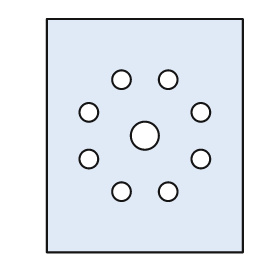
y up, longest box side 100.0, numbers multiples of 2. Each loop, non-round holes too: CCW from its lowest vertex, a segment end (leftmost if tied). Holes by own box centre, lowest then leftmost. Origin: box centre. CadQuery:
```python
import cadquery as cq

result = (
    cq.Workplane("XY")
    .moveTo(-42.0, -50.0)
    .lineTo(42.0, -50.0)
    .lineTo(42.0, 50.0)
    .lineTo(-42.0, 50.0)
    .close()
    .moveTo(-10.0, -24.0)
    .circle(4.0)
    .moveTo(10.0, -24.0)
    .circle(4.0)
    .moveTo(-24.0, -10.0)
    .circle(4.0)
    .moveTo(24.0, -10.0)
    .circle(4.0)
    .moveTo(0.0, 0.0)
    .circle(6.0)
    .moveTo(-24.0, 10.0)
    .circle(4.0)
    .moveTo(24.0, 10.0)
    .circle(4.0)
    .moveTo(-10.0, 24.0)
    .circle(4.0)
    .moveTo(10.0, 24.0)
    .circle(4.0)
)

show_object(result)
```